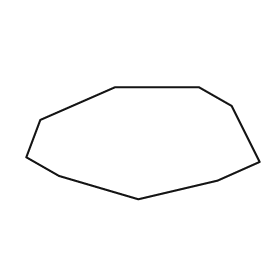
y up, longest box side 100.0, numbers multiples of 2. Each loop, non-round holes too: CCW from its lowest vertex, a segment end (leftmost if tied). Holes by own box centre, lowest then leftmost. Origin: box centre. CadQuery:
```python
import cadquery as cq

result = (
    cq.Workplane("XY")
    .moveTo(-2.0, -24.0)
    .lineTo(32.0, -16.0)
    .lineTo(50.0, -8.0)
    .lineTo(38.0, 16.0)
    .lineTo(24.0, 24.0)
    .lineTo(-12.0, 24.0)
    .lineTo(-44.0, 10.0)
    .lineTo(-50.0, -6.0)
    .lineTo(-36.0, -14.0)
    .close()
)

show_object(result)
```